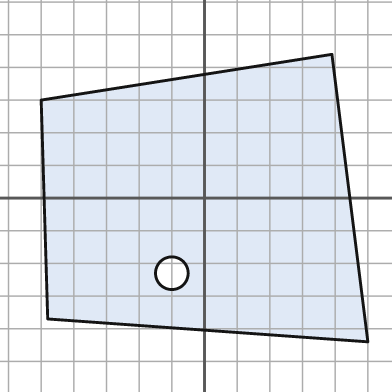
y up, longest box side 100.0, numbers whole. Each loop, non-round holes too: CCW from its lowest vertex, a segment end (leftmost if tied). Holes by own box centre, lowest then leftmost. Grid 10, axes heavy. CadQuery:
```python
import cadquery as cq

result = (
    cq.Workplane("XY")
    .moveTo(50.0, -44.0)
    .lineTo(39.0, 44.0)
    .lineTo(-50.0, 30.0)
    .lineTo(-48.0, -37.0)
    .close()
    .moveTo(-10.0, -23.0)
    .circle(5.0)
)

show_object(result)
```